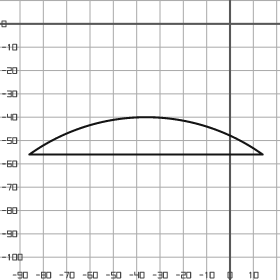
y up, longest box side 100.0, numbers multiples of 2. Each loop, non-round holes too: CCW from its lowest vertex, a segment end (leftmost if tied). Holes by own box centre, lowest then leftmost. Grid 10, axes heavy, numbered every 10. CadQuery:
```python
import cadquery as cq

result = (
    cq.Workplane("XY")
    .moveTo(-86.0, -56.0)
    .lineTo(14.0, -56.0)
    .threePointArc((-36.0, -40.0), (-86.0, -56.0))
    .close()
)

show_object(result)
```